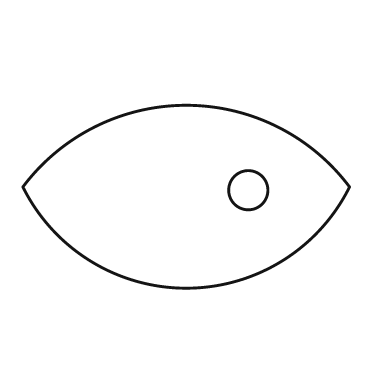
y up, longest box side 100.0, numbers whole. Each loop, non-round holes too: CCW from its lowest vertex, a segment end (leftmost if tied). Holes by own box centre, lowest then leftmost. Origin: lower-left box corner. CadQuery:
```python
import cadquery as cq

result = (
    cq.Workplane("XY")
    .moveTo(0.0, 31.0)
    .threePointArc((50.0, 0.0), (100.0, 31.0))
    .threePointArc((50.0, 56.0), (0.0, 31.0))
    .close()
    .moveTo(69.0, 30.0)
    .circle(6.0)
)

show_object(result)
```